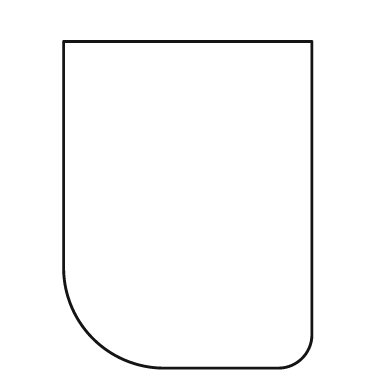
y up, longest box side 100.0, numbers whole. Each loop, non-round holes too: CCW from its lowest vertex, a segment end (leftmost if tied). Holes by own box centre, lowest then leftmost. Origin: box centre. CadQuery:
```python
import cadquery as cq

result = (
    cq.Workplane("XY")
    .moveTo(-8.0, -50.0)
    .lineTo(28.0, -50.0)
    .threePointArc((35.0, -47.0), (38.0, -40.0))
    .lineTo(38.0, 50.0)
    .lineTo(-38.0, 50.0)
    .lineTo(-38.0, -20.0)
    .threePointArc((-29.0, -41.0), (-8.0, -50.0))
    .close()
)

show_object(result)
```